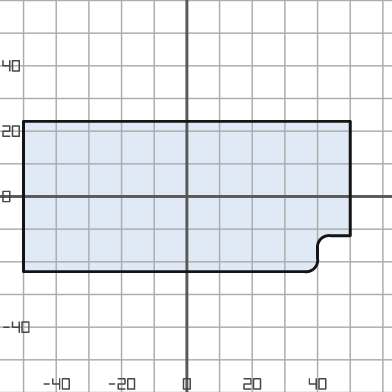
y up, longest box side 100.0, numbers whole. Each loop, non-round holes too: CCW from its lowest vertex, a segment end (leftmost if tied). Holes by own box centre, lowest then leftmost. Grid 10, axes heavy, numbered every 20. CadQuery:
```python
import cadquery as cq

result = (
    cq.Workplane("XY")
    .moveTo(-50.0, -23.0)
    .lineTo(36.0, -23.0)
    .threePointArc((39.0, -22.0), (40.0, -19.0))
    .lineTo(40.0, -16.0)
    .threePointArc((41.0, -13.0), (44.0, -12.0))
    .lineTo(50.0, -12.0)
    .lineTo(50.0, 23.0)
    .lineTo(-50.0, 23.0)
    .close()
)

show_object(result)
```